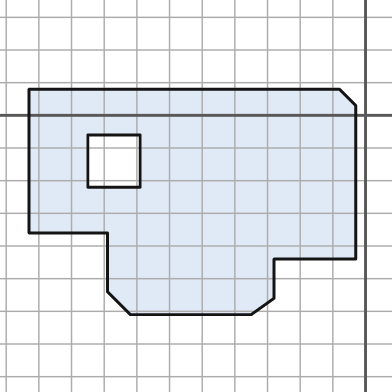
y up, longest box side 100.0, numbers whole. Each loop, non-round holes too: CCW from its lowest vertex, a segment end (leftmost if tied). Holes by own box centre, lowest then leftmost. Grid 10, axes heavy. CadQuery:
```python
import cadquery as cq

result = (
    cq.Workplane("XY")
    .moveTo(-72.0, -61.0)
    .lineTo(-35.0, -61.0)
    .lineTo(-28.0, -56.0)
    .lineTo(-28.0, -44.0)
    .lineTo(-3.0, -44.0)
    .lineTo(-3.0, 3.0)
    .lineTo(-8.0, 8.0)
    .lineTo(-103.0, 8.0)
    .lineTo(-103.0, -36.0)
    .lineTo(-79.0, -36.0)
    .lineTo(-79.0, -54.0)
    .close()
    .moveTo(-85.0, -22.0)
    .lineTo(-69.0, -22.0)
    .lineTo(-69.0, -6.0)
    .lineTo(-85.0, -6.0)
    .close()
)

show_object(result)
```